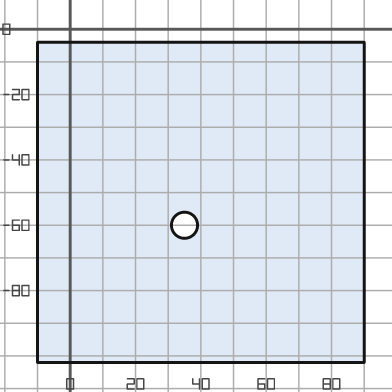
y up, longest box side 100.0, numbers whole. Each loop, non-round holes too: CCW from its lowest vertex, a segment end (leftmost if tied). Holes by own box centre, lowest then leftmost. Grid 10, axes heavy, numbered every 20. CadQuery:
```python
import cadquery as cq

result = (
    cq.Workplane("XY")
    .moveTo(-10.0, -102.0)
    .lineTo(90.0, -102.0)
    .lineTo(90.0, -4.0)
    .lineTo(-10.0, -4.0)
    .close()
    .moveTo(35.0, -60.0)
    .circle(4.0)
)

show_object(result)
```